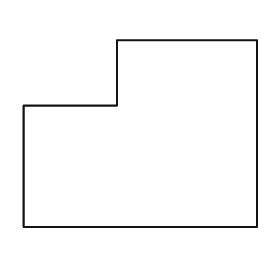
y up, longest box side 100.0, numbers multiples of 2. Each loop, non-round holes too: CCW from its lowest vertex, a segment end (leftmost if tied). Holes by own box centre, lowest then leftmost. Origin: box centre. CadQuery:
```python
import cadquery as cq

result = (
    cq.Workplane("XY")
    .moveTo(-50.0, -40.0)
    .lineTo(50.0, -40.0)
    .lineTo(50.0, 40.0)
    .lineTo(-10.0, 40.0)
    .lineTo(-10.0, 12.0)
    .lineTo(-50.0, 12.0)
    .close()
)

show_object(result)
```